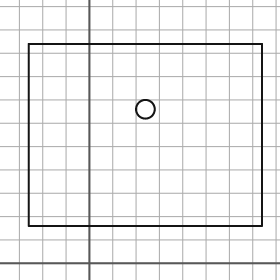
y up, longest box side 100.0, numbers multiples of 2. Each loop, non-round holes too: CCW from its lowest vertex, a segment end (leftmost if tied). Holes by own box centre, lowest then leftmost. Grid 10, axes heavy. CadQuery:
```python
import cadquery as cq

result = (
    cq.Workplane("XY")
    .moveTo(-26.0, 16.0)
    .lineTo(74.0, 16.0)
    .lineTo(74.0, 94.0)
    .lineTo(-26.0, 94.0)
    .close()
    .moveTo(24.0, 66.0)
    .circle(4.0)
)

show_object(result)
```